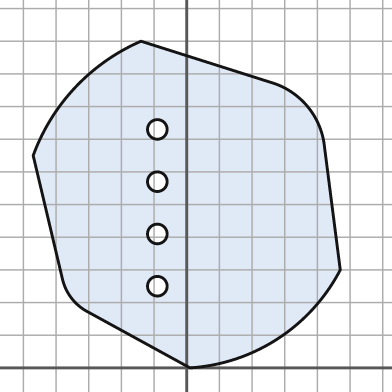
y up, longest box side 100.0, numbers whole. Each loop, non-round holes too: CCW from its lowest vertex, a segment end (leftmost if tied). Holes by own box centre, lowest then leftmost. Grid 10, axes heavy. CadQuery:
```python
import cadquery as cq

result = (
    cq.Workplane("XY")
    .moveTo(1.0, 0.0)
    .threePointArc((28.0, 9.0), (47.0, 30.0))
    .lineTo(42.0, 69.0)
    .threePointArc((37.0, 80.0), (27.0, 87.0))
    .lineTo(-14.0, 100.0)
    .threePointArc((-34.0, 86.0), (-47.0, 65.0))
    .lineTo(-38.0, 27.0)
    .threePointArc((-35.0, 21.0), (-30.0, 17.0))
    .close()
    .moveTo(-9.0, 25.0)
    .circle(3.0)
    .moveTo(-9.0, 41.0)
    .circle(3.0)
    .moveTo(-9.0, 57.0)
    .circle(3.0)
    .moveTo(-9.0, 73.0)
    .circle(3.0)
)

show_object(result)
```